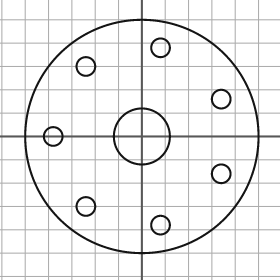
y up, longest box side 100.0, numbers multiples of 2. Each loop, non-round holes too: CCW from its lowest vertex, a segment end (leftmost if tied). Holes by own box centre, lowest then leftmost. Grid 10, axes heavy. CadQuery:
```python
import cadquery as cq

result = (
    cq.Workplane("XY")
    .moveTo(0.0, 0.0)
    .circle(50.0)
    .moveTo(8.0, -38.0)
    .circle(4.0)
    .moveTo(-24.0, -30.0)
    .circle(4.0)
    .moveTo(34.0, -16.0)
    .circle(4.0)
    .moveTo(-38.0, 0.0)
    .circle(4.0)
    .moveTo(0.0, 0.0)
    .circle(12.0)
    .moveTo(34.0, 16.0)
    .circle(4.0)
    .moveTo(-24.0, 30.0)
    .circle(4.0)
    .moveTo(8.0, 38.0)
    .circle(4.0)
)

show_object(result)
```